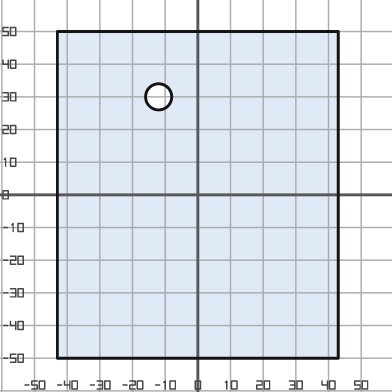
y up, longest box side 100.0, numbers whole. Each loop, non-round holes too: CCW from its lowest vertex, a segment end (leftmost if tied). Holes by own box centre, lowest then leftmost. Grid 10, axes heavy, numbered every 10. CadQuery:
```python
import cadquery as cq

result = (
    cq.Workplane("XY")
    .moveTo(-43.0, -50.0)
    .lineTo(43.0, -50.0)
    .lineTo(43.0, 50.0)
    .lineTo(-43.0, 50.0)
    .close()
    .moveTo(-12.0, 30.0)
    .circle(4.0)
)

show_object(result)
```